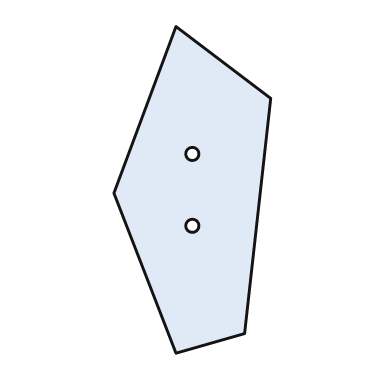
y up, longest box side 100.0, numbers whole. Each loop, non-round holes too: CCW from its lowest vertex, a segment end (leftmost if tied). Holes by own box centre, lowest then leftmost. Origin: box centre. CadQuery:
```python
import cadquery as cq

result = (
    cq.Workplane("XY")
    .moveTo(-5.0, -50.0)
    .lineTo(16.0, -44.0)
    .lineTo(24.0, 28.0)
    .lineTo(-5.0, 50.0)
    .lineTo(-24.0, -1.0)
    .close()
    .moveTo(0.0, -11.0)
    .circle(2.0)
    .moveTo(0.0, 11.0)
    .circle(2.0)
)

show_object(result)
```